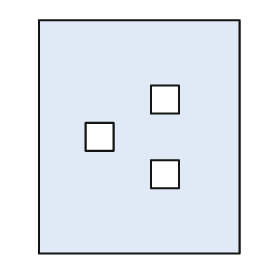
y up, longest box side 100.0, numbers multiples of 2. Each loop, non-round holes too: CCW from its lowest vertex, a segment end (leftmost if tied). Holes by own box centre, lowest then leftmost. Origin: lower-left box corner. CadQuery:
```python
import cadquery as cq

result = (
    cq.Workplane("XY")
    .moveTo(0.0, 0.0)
    .lineTo(86.0, 0.0)
    .lineTo(86.0, 100.0)
    .lineTo(0.0, 100.0)
    .close()
    .moveTo(48.0, 28.0)
    .lineTo(60.0, 28.0)
    .lineTo(60.0, 40.0)
    .lineTo(48.0, 40.0)
    .close()
    .moveTo(20.0, 44.0)
    .lineTo(32.0, 44.0)
    .lineTo(32.0, 56.0)
    .lineTo(20.0, 56.0)
    .close()
    .moveTo(48.0, 60.0)
    .lineTo(60.0, 60.0)
    .lineTo(60.0, 72.0)
    .lineTo(48.0, 72.0)
    .close()
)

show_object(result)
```